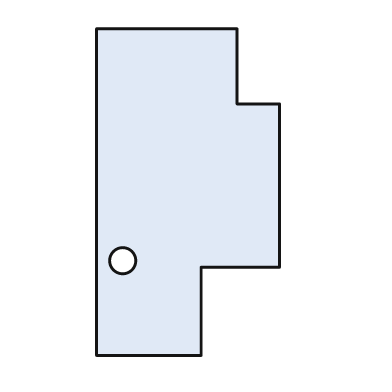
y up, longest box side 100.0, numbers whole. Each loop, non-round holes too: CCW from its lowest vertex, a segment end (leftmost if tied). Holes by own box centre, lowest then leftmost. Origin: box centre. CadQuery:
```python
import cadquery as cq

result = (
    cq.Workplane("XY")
    .moveTo(-28.0, -50.0)
    .lineTo(4.0, -50.0)
    .lineTo(4.0, -23.0)
    .lineTo(28.0, -23.0)
    .lineTo(28.0, 27.0)
    .lineTo(15.0, 27.0)
    .lineTo(15.0, 50.0)
    .lineTo(-28.0, 50.0)
    .close()
    .moveTo(-20.0, -21.0)
    .circle(4.0)
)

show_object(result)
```